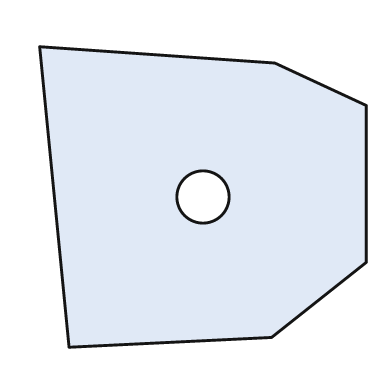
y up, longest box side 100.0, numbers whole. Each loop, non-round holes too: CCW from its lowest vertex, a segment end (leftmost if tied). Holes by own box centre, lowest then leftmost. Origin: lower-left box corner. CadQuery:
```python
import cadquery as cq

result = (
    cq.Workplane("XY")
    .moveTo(9.0, 0.0)
    .lineTo(71.0, 3.0)
    .lineTo(100.0, 26.0)
    .lineTo(100.0, 74.0)
    .lineTo(72.0, 87.0)
    .lineTo(0.0, 92.0)
    .close()
    .moveTo(50.0, 46.0)
    .circle(8.0)
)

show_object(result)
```